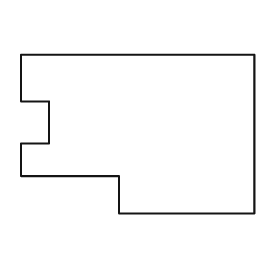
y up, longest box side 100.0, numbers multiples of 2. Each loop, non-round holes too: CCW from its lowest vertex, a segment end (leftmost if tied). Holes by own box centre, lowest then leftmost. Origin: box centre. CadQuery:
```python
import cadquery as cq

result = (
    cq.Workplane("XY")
    .moveTo(-8.0, -34.0)
    .lineTo(50.0, -34.0)
    .lineTo(50.0, 34.0)
    .lineTo(-50.0, 34.0)
    .lineTo(-50.0, 14.0)
    .lineTo(-38.0, 14.0)
    .lineTo(-38.0, -4.0)
    .lineTo(-50.0, -4.0)
    .lineTo(-50.0, -18.0)
    .lineTo(-8.0, -18.0)
    .close()
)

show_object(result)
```